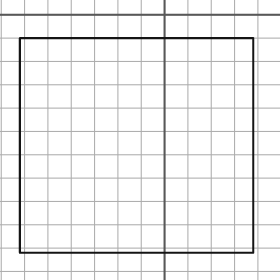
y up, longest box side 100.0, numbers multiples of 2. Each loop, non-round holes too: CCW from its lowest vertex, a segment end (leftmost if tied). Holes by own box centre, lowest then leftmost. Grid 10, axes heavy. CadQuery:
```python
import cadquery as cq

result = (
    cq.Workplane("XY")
    .moveTo(-62.0, -102.0)
    .lineTo(38.0, -102.0)
    .lineTo(38.0, -10.0)
    .lineTo(-62.0, -10.0)
    .close()
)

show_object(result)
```